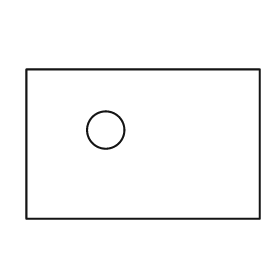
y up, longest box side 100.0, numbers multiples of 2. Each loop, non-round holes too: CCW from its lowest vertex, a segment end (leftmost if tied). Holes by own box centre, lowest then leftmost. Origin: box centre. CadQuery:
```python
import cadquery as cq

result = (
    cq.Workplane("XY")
    .moveTo(-50.0, -32.0)
    .lineTo(50.0, -32.0)
    .lineTo(50.0, 32.0)
    .lineTo(-50.0, 32.0)
    .close()
    .moveTo(-16.0, 6.0)
    .circle(8.0)
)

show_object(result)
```